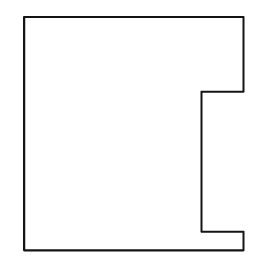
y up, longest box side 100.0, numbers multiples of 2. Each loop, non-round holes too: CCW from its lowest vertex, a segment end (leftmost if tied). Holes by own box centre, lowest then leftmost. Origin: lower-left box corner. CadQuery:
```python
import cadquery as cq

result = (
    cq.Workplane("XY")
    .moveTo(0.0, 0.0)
    .lineTo(94.0, 0.0)
    .lineTo(94.0, 8.0)
    .lineTo(76.0, 8.0)
    .lineTo(76.0, 68.0)
    .lineTo(94.0, 68.0)
    .lineTo(94.0, 100.0)
    .lineTo(0.0, 100.0)
    .close()
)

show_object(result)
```